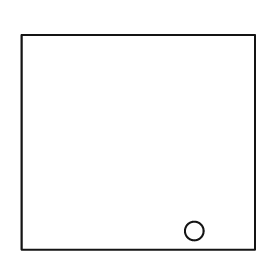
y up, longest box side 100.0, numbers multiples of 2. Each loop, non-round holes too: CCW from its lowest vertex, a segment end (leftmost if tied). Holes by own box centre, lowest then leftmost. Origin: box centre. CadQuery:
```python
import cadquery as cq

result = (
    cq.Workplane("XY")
    .moveTo(-50.0, -46.0)
    .lineTo(50.0, -46.0)
    .lineTo(50.0, 46.0)
    .lineTo(-50.0, 46.0)
    .close()
    .moveTo(24.0, -38.0)
    .circle(4.0)
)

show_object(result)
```